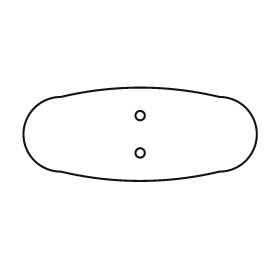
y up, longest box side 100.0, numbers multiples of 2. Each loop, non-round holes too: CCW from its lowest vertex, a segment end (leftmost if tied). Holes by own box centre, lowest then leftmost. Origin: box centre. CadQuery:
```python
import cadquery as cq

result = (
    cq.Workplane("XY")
    .moveTo(-34.0, -16.0)
    .threePointArc((0.0, -20.0), (34.0, -16.0))
    .threePointArc((50.0, 0.0), (34.0, 16.0))
    .threePointArc((0.0, 20.0), (-34.0, 16.0))
    .threePointArc((-50.0, 0.0), (-34.0, -16.0))
    .close()
    .moveTo(0.0, -8.0)
    .circle(2.0)
    .moveTo(0.0, 8.0)
    .circle(2.0)
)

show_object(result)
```